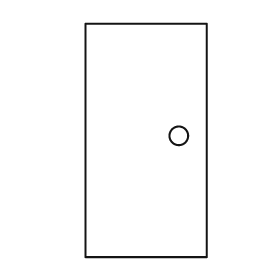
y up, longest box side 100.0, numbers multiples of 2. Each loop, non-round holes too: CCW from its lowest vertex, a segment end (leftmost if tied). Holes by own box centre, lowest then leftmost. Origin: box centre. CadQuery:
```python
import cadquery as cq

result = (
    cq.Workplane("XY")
    .moveTo(-26.0, -50.0)
    .lineTo(26.0, -50.0)
    .lineTo(26.0, 50.0)
    .lineTo(-26.0, 50.0)
    .close()
    .moveTo(14.0, 2.0)
    .circle(4.0)
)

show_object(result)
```